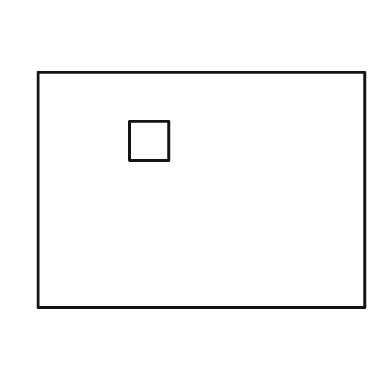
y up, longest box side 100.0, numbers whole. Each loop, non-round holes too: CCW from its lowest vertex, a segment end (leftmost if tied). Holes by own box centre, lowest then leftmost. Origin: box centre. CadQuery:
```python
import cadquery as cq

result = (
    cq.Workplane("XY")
    .moveTo(-50.0, -36.0)
    .lineTo(50.0, -36.0)
    .lineTo(50.0, 36.0)
    .lineTo(-50.0, 36.0)
    .close()
    .moveTo(-22.0, 9.0)
    .lineTo(-10.0, 9.0)
    .lineTo(-10.0, 21.0)
    .lineTo(-22.0, 21.0)
    .close()
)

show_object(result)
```